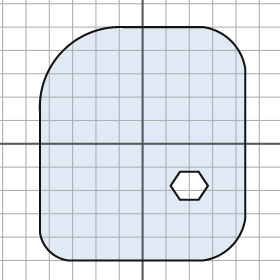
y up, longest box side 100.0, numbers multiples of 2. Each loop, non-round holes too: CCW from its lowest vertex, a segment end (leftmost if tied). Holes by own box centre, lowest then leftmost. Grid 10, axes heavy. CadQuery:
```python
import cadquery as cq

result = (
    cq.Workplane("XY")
    .moveTo(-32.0, -50.0)
    .lineTo(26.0, -50.0)
    .threePointArc((38.0, -44.0), (44.0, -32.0))
    .lineTo(44.0, 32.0)
    .threePointArc((38.0, 44.0), (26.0, 50.0))
    .lineTo(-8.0, 50.0)
    .threePointArc((-34.0, 40.0), (-44.0, 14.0))
    .lineTo(-44.0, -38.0)
    .threePointArc((-40.0, -46.0), (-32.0, -50.0))
    .close()
    .moveTo(16.0, -24.0)
    .lineTo(24.0, -24.0)
    .lineTo(28.0, -18.0)
    .lineTo(24.0, -12.0)
    .lineTo(16.0, -12.0)
    .lineTo(12.0, -18.0)
    .close()
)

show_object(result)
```